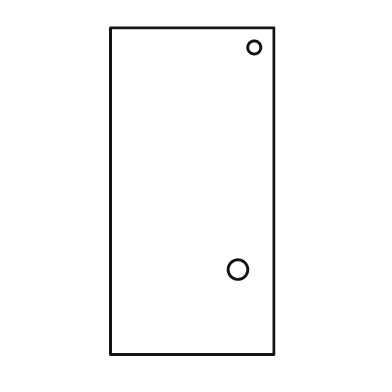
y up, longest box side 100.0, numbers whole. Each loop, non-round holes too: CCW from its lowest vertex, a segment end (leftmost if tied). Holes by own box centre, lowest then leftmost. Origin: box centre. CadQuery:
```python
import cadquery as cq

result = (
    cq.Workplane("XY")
    .moveTo(-25.0, -50.0)
    .lineTo(25.0, -50.0)
    .lineTo(25.0, 50.0)
    .lineTo(-25.0, 50.0)
    .close()
    .moveTo(14.0, -24.0)
    .circle(3.0)
    .moveTo(19.0, 44.0)
    .circle(2.0)
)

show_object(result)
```